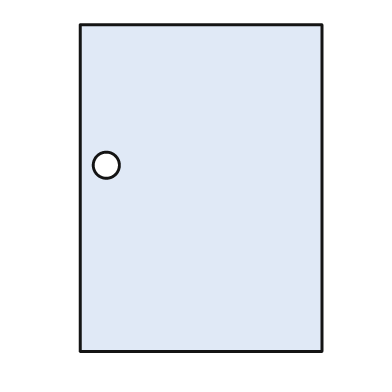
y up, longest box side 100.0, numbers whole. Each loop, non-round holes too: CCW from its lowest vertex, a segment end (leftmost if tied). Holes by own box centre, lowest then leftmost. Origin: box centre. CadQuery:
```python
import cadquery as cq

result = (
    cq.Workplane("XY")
    .moveTo(-37.0, -50.0)
    .lineTo(37.0, -50.0)
    .lineTo(37.0, 50.0)
    .lineTo(-37.0, 50.0)
    .close()
    .moveTo(-29.0, 7.0)
    .circle(4.0)
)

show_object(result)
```